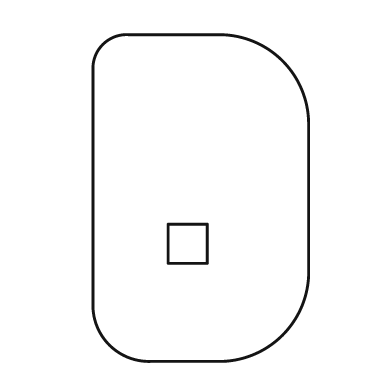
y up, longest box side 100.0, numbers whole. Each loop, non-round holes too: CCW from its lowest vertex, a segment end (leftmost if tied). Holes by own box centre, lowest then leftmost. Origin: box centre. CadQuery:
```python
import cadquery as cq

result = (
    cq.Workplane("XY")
    .moveTo(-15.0, -50.0)
    .lineTo(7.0, -50.0)
    .threePointArc((25.0, -42.0), (33.0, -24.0))
    .lineTo(33.0, 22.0)
    .threePointArc((25.0, 42.0), (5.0, 50.0))
    .lineTo(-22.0, 50.0)
    .threePointArc((-30.0, 47.0), (-33.0, 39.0))
    .lineTo(-33.0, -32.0)
    .threePointArc((-28.0, -45.0), (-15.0, -50.0))
    .close()
    .moveTo(-10.0, -20.0)
    .lineTo(2.0, -20.0)
    .lineTo(2.0, -8.0)
    .lineTo(-10.0, -8.0)
    .close()
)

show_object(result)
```